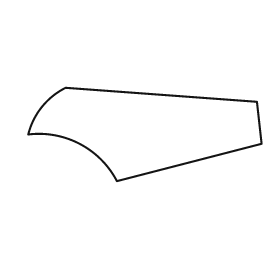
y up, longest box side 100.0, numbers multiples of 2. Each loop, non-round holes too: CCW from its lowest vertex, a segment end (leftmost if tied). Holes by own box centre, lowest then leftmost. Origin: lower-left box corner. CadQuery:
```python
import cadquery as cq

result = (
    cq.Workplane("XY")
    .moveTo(38.0, 0.0)
    .lineTo(100.0, 16.0)
    .lineTo(98.0, 34.0)
    .lineTo(16.0, 40.0)
    .threePointArc((6.0, 32.0), (0.0, 20.0))
    .threePointArc((22.0, 16.0), (38.0, 0.0))
    .close()
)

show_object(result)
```